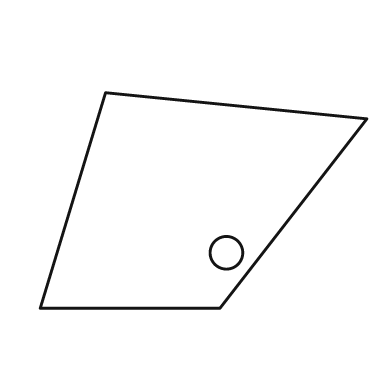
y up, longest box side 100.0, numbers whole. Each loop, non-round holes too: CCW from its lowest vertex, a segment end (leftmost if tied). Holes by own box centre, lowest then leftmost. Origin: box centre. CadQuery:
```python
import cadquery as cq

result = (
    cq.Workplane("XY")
    .moveTo(-50.0, -33.0)
    .lineTo(5.0, -33.0)
    .lineTo(50.0, 25.0)
    .lineTo(-30.0, 33.0)
    .close()
    .moveTo(7.0, -16.0)
    .circle(5.0)
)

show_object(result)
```